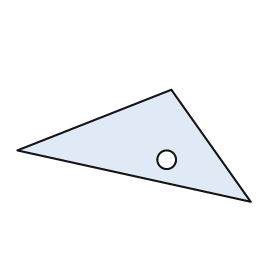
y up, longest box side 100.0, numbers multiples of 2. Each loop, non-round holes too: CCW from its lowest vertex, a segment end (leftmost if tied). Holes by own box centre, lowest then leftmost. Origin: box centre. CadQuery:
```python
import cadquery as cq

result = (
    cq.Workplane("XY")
    .moveTo(50.0, -24.0)
    .lineTo(16.0, 24.0)
    .lineTo(-50.0, -2.0)
    .close()
    .moveTo(14.0, -6.0)
    .circle(4.0)
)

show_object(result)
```